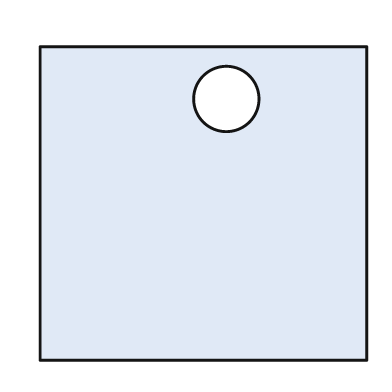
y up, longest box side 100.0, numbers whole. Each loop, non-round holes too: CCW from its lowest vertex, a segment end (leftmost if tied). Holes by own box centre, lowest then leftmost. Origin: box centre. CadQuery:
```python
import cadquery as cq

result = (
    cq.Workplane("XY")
    .moveTo(-50.0, -48.0)
    .lineTo(50.0, -48.0)
    .lineTo(50.0, 48.0)
    .lineTo(-50.0, 48.0)
    .close()
    .moveTo(7.0, 32.0)
    .circle(10.0)
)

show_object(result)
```